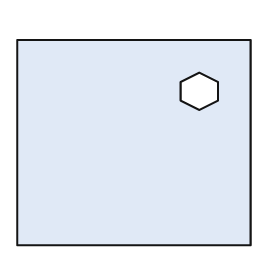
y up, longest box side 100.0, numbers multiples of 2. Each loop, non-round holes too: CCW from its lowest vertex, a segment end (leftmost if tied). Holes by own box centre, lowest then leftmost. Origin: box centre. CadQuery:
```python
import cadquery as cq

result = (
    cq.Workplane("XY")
    .moveTo(-50.0, -44.0)
    .lineTo(50.0, -44.0)
    .lineTo(50.0, 44.0)
    .lineTo(-50.0, 44.0)
    .close()
    .moveTo(28.0, 14.0)
    .lineTo(36.0, 18.0)
    .lineTo(36.0, 26.0)
    .lineTo(28.0, 30.0)
    .lineTo(20.0, 26.0)
    .lineTo(20.0, 18.0)
    .close()
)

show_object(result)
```